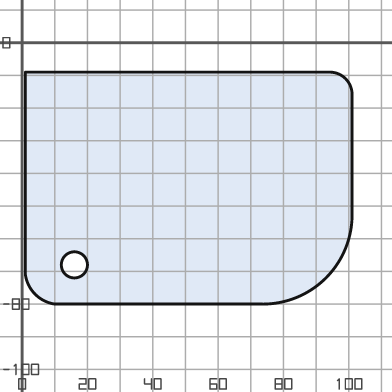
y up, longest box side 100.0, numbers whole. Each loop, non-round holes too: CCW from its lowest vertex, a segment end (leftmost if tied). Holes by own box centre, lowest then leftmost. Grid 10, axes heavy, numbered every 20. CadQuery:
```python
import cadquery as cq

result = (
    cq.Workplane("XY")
    .moveTo(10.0, -80.0)
    .lineTo(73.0, -80.0)
    .threePointArc((93.0, -72.0), (101.0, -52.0))
    .lineTo(101.0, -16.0)
    .threePointArc((99.0, -11.0), (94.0, -9.0))
    .lineTo(1.0, -9.0)
    .lineTo(1.0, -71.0)
    .threePointArc((4.0, -77.0), (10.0, -80.0))
    .close()
    .moveTo(16.0, -68.0)
    .circle(4.0)
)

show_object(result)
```